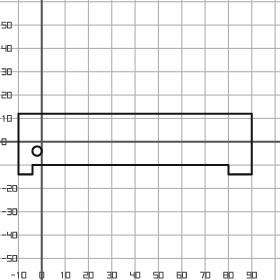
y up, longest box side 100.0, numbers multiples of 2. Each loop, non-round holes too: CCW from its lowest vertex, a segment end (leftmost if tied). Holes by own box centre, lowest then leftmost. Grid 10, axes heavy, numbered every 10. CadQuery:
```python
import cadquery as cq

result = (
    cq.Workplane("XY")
    .moveTo(-10.0, -14.0)
    .lineTo(-4.0, -14.0)
    .lineTo(-4.0, -10.0)
    .lineTo(80.0, -10.0)
    .lineTo(80.0, -14.0)
    .lineTo(90.0, -14.0)
    .lineTo(90.0, 12.0)
    .lineTo(-10.0, 12.0)
    .close()
    .moveTo(-2.0, -4.0)
    .circle(2.0)
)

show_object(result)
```